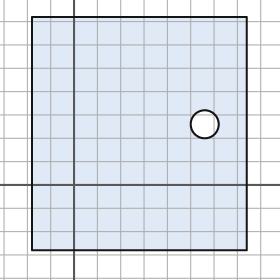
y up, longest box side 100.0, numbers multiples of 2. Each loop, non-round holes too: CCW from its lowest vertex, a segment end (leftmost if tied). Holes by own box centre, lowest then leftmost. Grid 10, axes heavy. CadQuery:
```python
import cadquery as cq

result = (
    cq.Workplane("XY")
    .moveTo(-18.0, -28.0)
    .lineTo(74.0, -28.0)
    .lineTo(74.0, 72.0)
    .lineTo(-18.0, 72.0)
    .close()
    .moveTo(56.0, 26.0)
    .circle(6.0)
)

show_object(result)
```